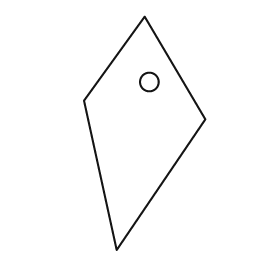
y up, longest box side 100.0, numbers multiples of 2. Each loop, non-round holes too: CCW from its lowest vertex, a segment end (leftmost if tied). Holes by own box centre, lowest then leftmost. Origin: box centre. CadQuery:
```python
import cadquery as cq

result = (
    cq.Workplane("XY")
    .moveTo(-12.0, -50.0)
    .lineTo(26.0, 6.0)
    .lineTo(0.0, 50.0)
    .lineTo(-26.0, 14.0)
    .close()
    .moveTo(2.0, 22.0)
    .circle(4.0)
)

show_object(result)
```